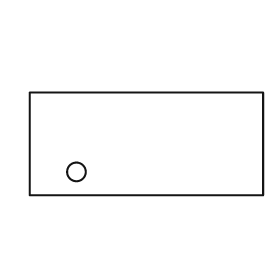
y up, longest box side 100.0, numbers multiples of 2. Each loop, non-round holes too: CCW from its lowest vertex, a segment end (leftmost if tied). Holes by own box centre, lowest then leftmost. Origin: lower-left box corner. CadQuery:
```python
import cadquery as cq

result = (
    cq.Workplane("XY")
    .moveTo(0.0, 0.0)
    .lineTo(100.0, 0.0)
    .lineTo(100.0, 44.0)
    .lineTo(0.0, 44.0)
    .close()
    .moveTo(20.0, 10.0)
    .circle(4.0)
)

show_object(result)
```